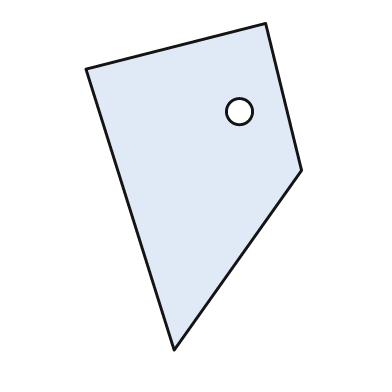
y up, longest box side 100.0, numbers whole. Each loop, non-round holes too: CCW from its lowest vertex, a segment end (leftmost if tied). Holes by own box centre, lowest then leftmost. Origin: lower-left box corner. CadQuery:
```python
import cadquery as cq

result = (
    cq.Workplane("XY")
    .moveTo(27.0, 0.0)
    .lineTo(66.0, 55.0)
    .lineTo(55.0, 100.0)
    .lineTo(0.0, 86.0)
    .close()
    .moveTo(47.0, 73.0)
    .circle(4.0)
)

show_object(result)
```